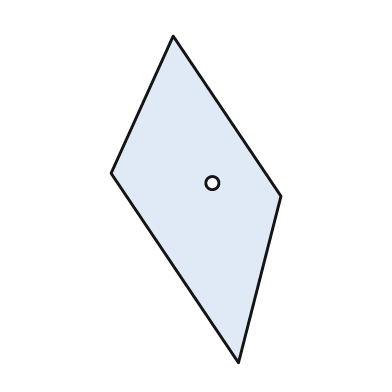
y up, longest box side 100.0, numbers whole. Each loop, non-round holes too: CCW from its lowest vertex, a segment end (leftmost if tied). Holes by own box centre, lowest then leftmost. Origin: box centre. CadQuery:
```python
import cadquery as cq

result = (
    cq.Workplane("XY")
    .moveTo(13.0, -50.0)
    .lineTo(26.0, 1.0)
    .lineTo(-7.0, 50.0)
    .lineTo(-26.0, 8.0)
    .close()
    .moveTo(5.0, 5.0)
    .circle(2.0)
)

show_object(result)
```